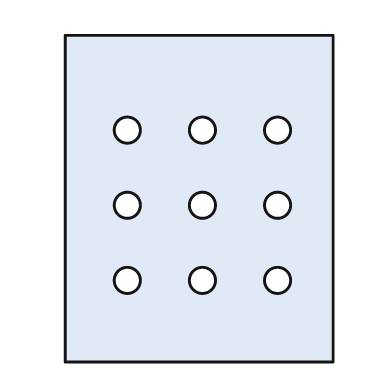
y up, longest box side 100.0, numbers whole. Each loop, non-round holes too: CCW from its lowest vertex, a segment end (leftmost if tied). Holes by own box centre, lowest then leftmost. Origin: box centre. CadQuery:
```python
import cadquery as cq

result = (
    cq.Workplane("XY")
    .moveTo(-41.0, -50.0)
    .lineTo(41.0, -50.0)
    .lineTo(41.0, 50.0)
    .lineTo(-41.0, 50.0)
    .close()
    .moveTo(-22.0, -25.0)
    .circle(4.0)
    .moveTo(1.0, -25.0)
    .circle(4.0)
    .moveTo(24.0, -25.0)
    .circle(4.0)
    .moveTo(-22.0, -2.0)
    .circle(4.0)
    .moveTo(1.0, -2.0)
    .circle(4.0)
    .moveTo(24.0, -2.0)
    .circle(4.0)
    .moveTo(-22.0, 21.0)
    .circle(4.0)
    .moveTo(1.0, 21.0)
    .circle(4.0)
    .moveTo(24.0, 21.0)
    .circle(4.0)
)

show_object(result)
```